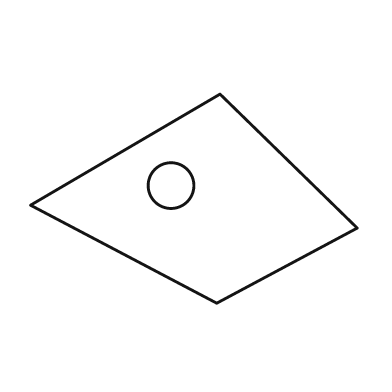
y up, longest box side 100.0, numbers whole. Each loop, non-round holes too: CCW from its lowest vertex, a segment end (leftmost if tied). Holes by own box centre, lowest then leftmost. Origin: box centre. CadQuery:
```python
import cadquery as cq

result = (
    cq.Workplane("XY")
    .moveTo(7.0, -32.0)
    .lineTo(50.0, -9.0)
    .lineTo(8.0, 32.0)
    .lineTo(-50.0, -2.0)
    .close()
    .moveTo(-7.0, 4.0)
    .circle(7.0)
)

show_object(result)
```